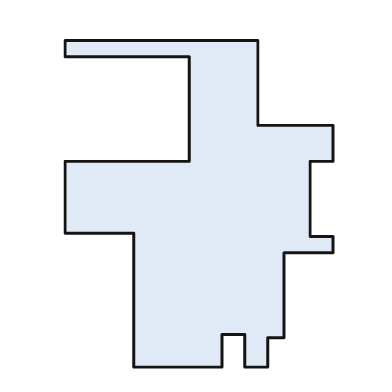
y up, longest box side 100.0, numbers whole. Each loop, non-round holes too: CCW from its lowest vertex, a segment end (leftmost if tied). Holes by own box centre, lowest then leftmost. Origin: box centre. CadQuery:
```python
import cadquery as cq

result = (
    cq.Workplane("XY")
    .moveTo(-20.0, -50.0)
    .lineTo(7.0, -50.0)
    .lineTo(7.0, -40.0)
    .lineTo(14.0, -40.0)
    .lineTo(14.0, -50.0)
    .lineTo(21.0, -50.0)
    .lineTo(21.0, -41.0)
    .lineTo(26.0, -41.0)
    .lineTo(26.0, -15.0)
    .lineTo(41.0, -15.0)
    .lineTo(41.0, -10.0)
    .lineTo(34.0, -10.0)
    .lineTo(34.0, 13.0)
    .lineTo(41.0, 13.0)
    .lineTo(41.0, 24.0)
    .lineTo(18.0, 24.0)
    .lineTo(18.0, 50.0)
    .lineTo(-41.0, 50.0)
    .lineTo(-41.0, 45.0)
    .lineTo(-3.0, 45.0)
    .lineTo(-3.0, 13.0)
    .lineTo(-41.0, 13.0)
    .lineTo(-41.0, -9.0)
    .lineTo(-20.0, -9.0)
    .close()
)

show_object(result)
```